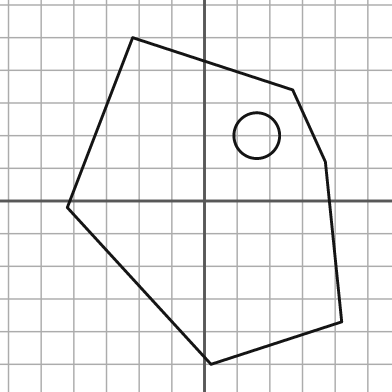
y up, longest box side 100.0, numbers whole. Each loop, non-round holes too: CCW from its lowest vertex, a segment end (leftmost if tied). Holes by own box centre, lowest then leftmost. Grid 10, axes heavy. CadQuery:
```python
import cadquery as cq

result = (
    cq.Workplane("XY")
    .moveTo(2.0, -50.0)
    .lineTo(42.0, -37.0)
    .lineTo(37.0, 12.0)
    .lineTo(27.0, 34.0)
    .lineTo(-22.0, 50.0)
    .lineTo(-42.0, -2.0)
    .close()
    .moveTo(16.0, 20.0)
    .circle(7.0)
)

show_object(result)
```